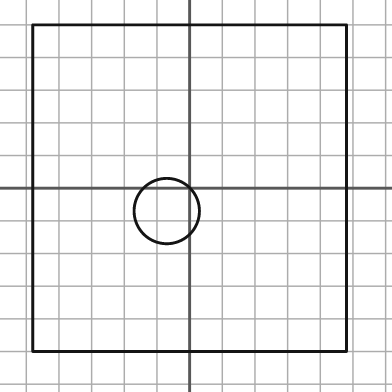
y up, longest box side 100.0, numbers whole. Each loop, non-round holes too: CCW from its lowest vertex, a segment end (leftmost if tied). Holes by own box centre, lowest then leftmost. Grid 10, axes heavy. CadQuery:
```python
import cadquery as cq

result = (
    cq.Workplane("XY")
    .moveTo(-48.0, -50.0)
    .lineTo(48.0, -50.0)
    .lineTo(48.0, 50.0)
    .lineTo(-48.0, 50.0)
    .close()
    .moveTo(-7.0, -7.0)
    .circle(10.0)
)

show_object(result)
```